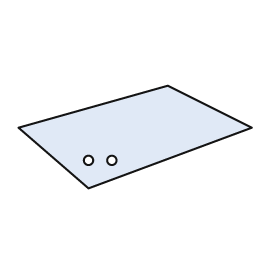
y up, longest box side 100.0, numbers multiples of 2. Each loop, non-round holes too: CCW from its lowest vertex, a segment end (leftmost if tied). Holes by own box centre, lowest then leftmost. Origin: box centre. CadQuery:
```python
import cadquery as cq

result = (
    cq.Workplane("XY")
    .moveTo(-20.0, -22.0)
    .lineTo(50.0, 4.0)
    .lineTo(14.0, 22.0)
    .lineTo(-50.0, 4.0)
    .close()
    .moveTo(-20.0, -10.0)
    .circle(2.0)
    .moveTo(-10.0, -10.0)
    .circle(2.0)
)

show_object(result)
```